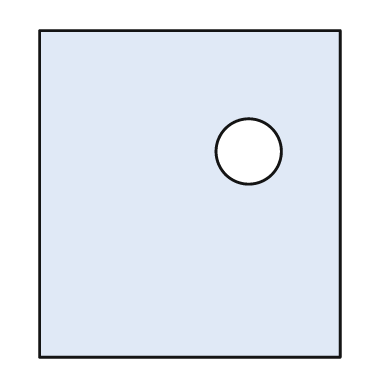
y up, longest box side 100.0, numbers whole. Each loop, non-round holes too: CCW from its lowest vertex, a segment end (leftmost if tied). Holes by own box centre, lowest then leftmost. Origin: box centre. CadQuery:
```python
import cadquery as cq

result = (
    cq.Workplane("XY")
    .moveTo(-46.0, -50.0)
    .lineTo(46.0, -50.0)
    .lineTo(46.0, 50.0)
    .lineTo(-46.0, 50.0)
    .close()
    .moveTo(18.0, 13.0)
    .circle(10.0)
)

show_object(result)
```